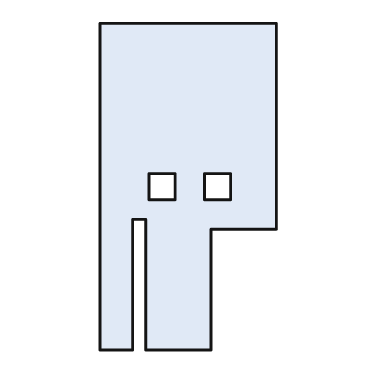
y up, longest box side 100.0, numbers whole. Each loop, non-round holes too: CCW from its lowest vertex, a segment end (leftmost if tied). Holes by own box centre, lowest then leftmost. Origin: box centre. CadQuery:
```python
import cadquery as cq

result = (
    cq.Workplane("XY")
    .moveTo(-27.0, -50.0)
    .lineTo(-17.0, -50.0)
    .lineTo(-17.0, -10.0)
    .lineTo(-13.0, -10.0)
    .lineTo(-13.0, -50.0)
    .lineTo(7.0, -50.0)
    .lineTo(7.0, -13.0)
    .lineTo(27.0, -13.0)
    .lineTo(27.0, 50.0)
    .lineTo(-27.0, 50.0)
    .close()
    .moveTo(-12.0, -4.0)
    .lineTo(-4.0, -4.0)
    .lineTo(-4.0, 4.0)
    .lineTo(-12.0, 4.0)
    .close()
    .moveTo(5.0, -4.0)
    .lineTo(13.0, -4.0)
    .lineTo(13.0, 4.0)
    .lineTo(5.0, 4.0)
    .close()
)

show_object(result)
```